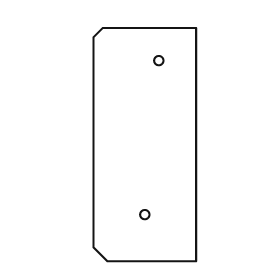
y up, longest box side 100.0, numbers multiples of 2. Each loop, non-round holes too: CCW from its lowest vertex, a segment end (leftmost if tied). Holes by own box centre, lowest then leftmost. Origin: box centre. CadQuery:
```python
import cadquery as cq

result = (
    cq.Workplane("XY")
    .moveTo(-16.0, -50.0)
    .lineTo(22.0, -50.0)
    .lineTo(22.0, 50.0)
    .lineTo(-18.0, 50.0)
    .lineTo(-22.0, 46.0)
    .lineTo(-22.0, -44.0)
    .close()
    .moveTo(0.0, -30.0)
    .circle(2.0)
    .moveTo(6.0, 36.0)
    .circle(2.0)
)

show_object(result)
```